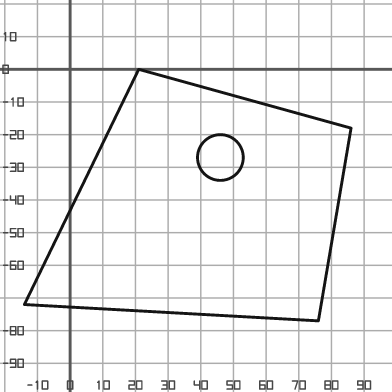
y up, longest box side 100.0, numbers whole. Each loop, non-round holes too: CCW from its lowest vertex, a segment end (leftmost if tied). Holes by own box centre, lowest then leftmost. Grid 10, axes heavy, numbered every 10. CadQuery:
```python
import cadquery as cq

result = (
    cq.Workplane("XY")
    .moveTo(76.0, -77.0)
    .lineTo(86.0, -18.0)
    .lineTo(21.0, 0.0)
    .lineTo(-14.0, -72.0)
    .close()
    .moveTo(46.0, -27.0)
    .circle(7.0)
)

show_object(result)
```